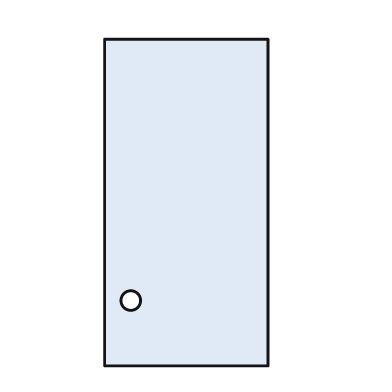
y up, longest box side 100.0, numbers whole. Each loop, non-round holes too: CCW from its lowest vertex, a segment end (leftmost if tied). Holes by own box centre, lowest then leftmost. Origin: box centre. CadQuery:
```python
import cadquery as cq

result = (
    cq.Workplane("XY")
    .moveTo(-25.0, -50.0)
    .lineTo(25.0, -50.0)
    .lineTo(25.0, 50.0)
    .lineTo(-25.0, 50.0)
    .close()
    .moveTo(-17.0, -30.0)
    .circle(3.0)
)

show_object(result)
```